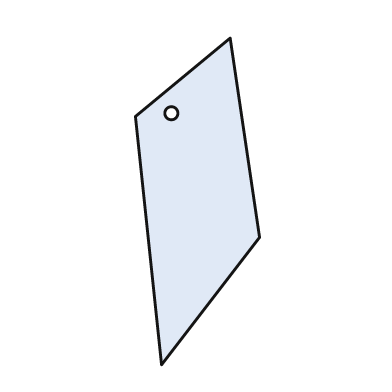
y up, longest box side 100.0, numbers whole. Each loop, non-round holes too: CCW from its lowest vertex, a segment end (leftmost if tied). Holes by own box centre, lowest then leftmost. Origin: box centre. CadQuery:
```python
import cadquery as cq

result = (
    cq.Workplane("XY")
    .moveTo(-11.0, -50.0)
    .lineTo(19.0, -11.0)
    .lineTo(10.0, 50.0)
    .lineTo(-19.0, 26.0)
    .close()
    .moveTo(-8.0, 27.0)
    .circle(2.0)
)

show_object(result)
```